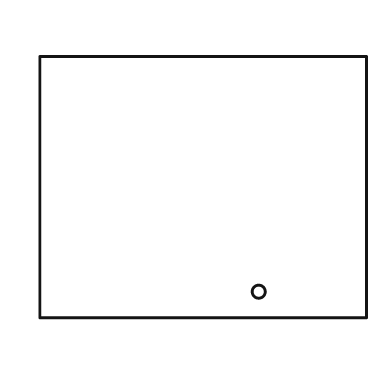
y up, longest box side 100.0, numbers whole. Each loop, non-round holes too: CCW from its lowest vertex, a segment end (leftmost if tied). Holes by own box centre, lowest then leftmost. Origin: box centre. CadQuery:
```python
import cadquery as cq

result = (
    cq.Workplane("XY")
    .moveTo(-50.0, -40.0)
    .lineTo(50.0, -40.0)
    .lineTo(50.0, 40.0)
    .lineTo(-50.0, 40.0)
    .close()
    .moveTo(17.0, -32.0)
    .circle(2.0)
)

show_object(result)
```